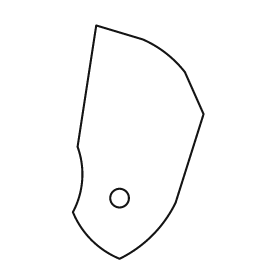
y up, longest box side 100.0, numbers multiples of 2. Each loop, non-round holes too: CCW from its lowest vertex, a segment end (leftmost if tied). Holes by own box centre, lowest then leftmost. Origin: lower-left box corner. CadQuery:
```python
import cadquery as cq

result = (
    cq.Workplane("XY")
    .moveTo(20.0, 0.0)
    .threePointArc((34.0, 10.0), (44.0, 24.0))
    .lineTo(56.0, 62.0)
    .lineTo(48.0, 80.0)
    .threePointArc((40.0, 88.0), (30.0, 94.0))
    .lineTo(10.0, 100.0)
    .lineTo(2.0, 48.0)
    .threePointArc((4.0, 34.0), (0.0, 20.0))
    .threePointArc((8.0, 8.0), (20.0, 0.0))
    .close()
    .moveTo(20.0, 26.0)
    .circle(4.0)
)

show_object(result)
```